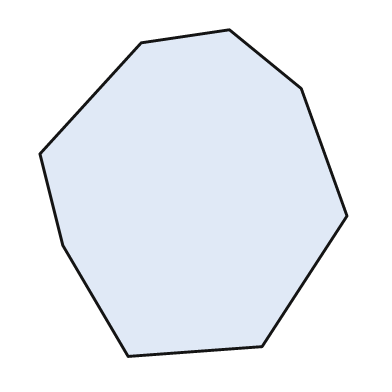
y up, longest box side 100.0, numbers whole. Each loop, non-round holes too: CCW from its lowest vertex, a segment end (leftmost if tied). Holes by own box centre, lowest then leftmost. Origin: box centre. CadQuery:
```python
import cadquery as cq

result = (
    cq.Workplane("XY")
    .moveTo(-20.0, -50.0)
    .lineTo(21.0, -47.0)
    .lineTo(47.0, -7.0)
    .lineTo(33.0, 32.0)
    .lineTo(11.0, 50.0)
    .lineTo(-16.0, 46.0)
    .lineTo(-47.0, 12.0)
    .lineTo(-40.0, -16.0)
    .close()
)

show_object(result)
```